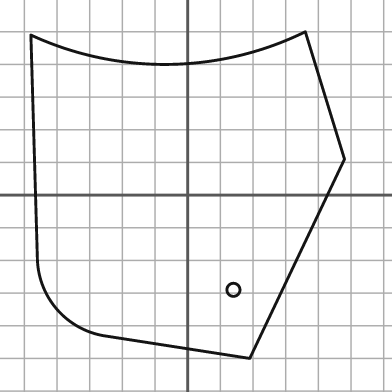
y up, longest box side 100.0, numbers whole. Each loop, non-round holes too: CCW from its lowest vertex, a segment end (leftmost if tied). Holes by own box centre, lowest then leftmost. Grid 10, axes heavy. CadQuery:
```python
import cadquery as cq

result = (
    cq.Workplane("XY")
    .moveTo(19.0, -50.0)
    .lineTo(48.0, 11.0)
    .lineTo(36.0, 50.0)
    .threePointArc((-6.0, 40.0), (-48.0, 49.0))
    .lineTo(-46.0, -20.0)
    .threePointArc((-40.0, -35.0), (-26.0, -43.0))
    .close()
    .moveTo(14.0, -29.0)
    .circle(2.0)
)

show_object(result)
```